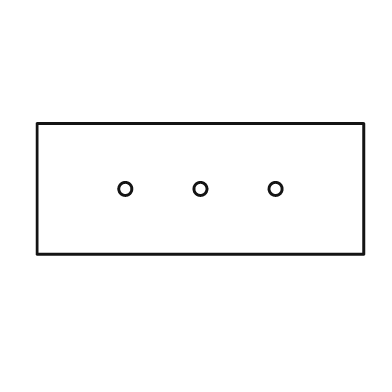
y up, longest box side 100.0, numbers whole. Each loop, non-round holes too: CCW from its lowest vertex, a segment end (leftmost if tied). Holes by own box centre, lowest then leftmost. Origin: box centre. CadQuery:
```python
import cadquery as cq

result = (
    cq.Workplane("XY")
    .moveTo(-50.0, -20.0)
    .lineTo(50.0, -20.0)
    .lineTo(50.0, 20.0)
    .lineTo(-50.0, 20.0)
    .close()
    .moveTo(-23.0, 0.0)
    .circle(2.0)
    .moveTo(0.0, 0.0)
    .circle(2.0)
    .moveTo(23.0, 0.0)
    .circle(2.0)
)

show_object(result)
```